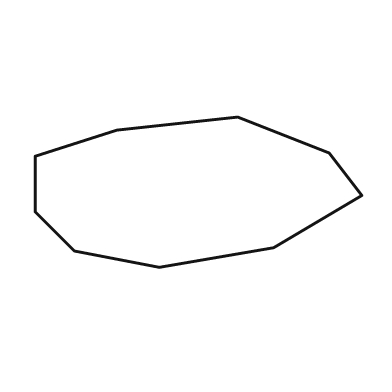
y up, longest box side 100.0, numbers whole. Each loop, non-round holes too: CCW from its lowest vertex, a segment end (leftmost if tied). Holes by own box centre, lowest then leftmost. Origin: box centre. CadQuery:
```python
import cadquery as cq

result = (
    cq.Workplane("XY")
    .moveTo(-12.0, -23.0)
    .lineTo(23.0, -17.0)
    .lineTo(50.0, -1.0)
    .lineTo(40.0, 12.0)
    .lineTo(12.0, 23.0)
    .lineTo(-25.0, 19.0)
    .lineTo(-50.0, 11.0)
    .lineTo(-50.0, -6.0)
    .lineTo(-38.0, -18.0)
    .close()
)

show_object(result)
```